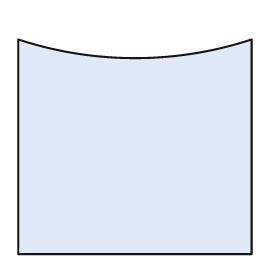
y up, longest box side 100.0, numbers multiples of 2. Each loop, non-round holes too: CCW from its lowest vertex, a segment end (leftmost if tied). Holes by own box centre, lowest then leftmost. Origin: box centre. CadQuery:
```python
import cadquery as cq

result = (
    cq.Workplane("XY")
    .moveTo(-50.0, -46.0)
    .lineTo(50.0, -46.0)
    .lineTo(50.0, 46.0)
    .threePointArc((0.0, 38.0), (-50.0, 46.0))
    .close()
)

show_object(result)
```